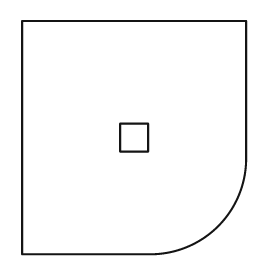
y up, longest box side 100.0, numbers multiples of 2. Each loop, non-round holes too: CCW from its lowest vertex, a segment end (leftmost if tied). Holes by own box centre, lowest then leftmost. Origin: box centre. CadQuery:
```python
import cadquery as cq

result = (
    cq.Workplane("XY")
    .moveTo(-48.0, -50.0)
    .lineTo(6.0, -50.0)
    .threePointArc((36.0, -38.0), (48.0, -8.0))
    .lineTo(48.0, 50.0)
    .lineTo(-48.0, 50.0)
    .close()
    .moveTo(-6.0, -6.0)
    .lineTo(6.0, -6.0)
    .lineTo(6.0, 6.0)
    .lineTo(-6.0, 6.0)
    .close()
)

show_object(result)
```